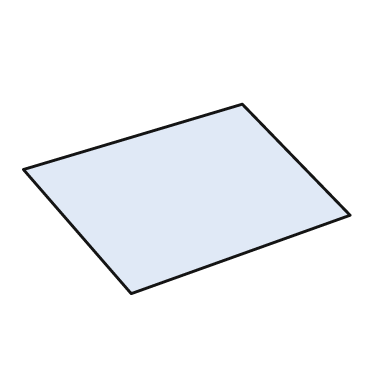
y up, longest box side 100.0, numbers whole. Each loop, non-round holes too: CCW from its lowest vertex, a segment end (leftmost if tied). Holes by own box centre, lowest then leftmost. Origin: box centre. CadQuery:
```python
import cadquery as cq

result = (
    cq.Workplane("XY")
    .moveTo(-17.0, -29.0)
    .lineTo(50.0, -5.0)
    .lineTo(17.0, 29.0)
    .lineTo(-50.0, 9.0)
    .close()
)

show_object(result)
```